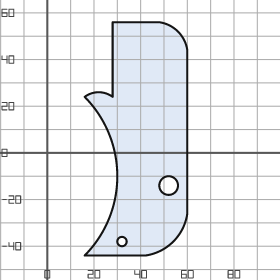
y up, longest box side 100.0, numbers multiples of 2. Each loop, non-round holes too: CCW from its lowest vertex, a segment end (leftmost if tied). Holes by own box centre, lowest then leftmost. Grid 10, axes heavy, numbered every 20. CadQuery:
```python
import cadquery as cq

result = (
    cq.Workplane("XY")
    .moveTo(16.0, -44.0)
    .lineTo(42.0, -44.0)
    .threePointArc((54.0, -38.0), (60.0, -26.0))
    .lineTo(60.0, 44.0)
    .threePointArc((56.0, 52.0), (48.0, 56.0))
    .lineTo(28.0, 56.0)
    .lineTo(28.0, 24.0)
    .threePointArc((22.0, 26.0), (16.0, 24.0))
    .threePointArc((30.0, -10.0), (16.0, -44.0))
    .close()
    .moveTo(32.0, -38.0)
    .circle(2.0)
    .moveTo(52.0, -14.0)
    .circle(4.0)
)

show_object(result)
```